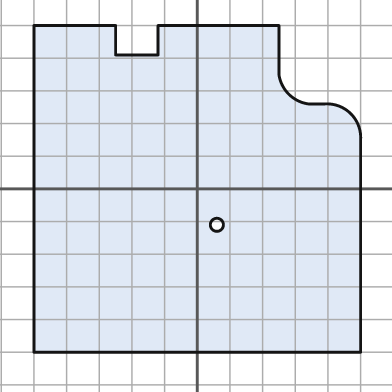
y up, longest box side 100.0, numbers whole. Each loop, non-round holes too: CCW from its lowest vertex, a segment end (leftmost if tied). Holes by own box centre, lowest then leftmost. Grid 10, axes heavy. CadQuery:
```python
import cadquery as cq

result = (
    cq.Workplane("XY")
    .moveTo(-50.0, -50.0)
    .lineTo(50.0, -50.0)
    .lineTo(50.0, 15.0)
    .threePointArc((47.0, 23.0), (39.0, 26.0))
    .lineTo(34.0, 26.0)
    .threePointArc((28.0, 29.0), (25.0, 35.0))
    .lineTo(25.0, 50.0)
    .lineTo(-12.0, 50.0)
    .lineTo(-12.0, 41.0)
    .lineTo(-25.0, 41.0)
    .lineTo(-25.0, 50.0)
    .lineTo(-50.0, 50.0)
    .close()
    .moveTo(6.0, -11.0)
    .circle(2.0)
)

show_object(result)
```